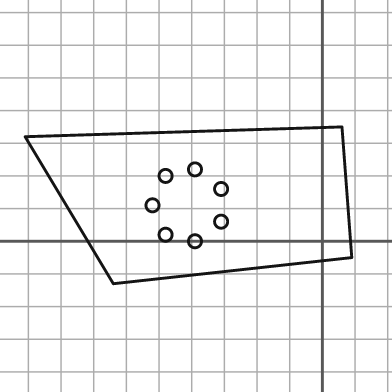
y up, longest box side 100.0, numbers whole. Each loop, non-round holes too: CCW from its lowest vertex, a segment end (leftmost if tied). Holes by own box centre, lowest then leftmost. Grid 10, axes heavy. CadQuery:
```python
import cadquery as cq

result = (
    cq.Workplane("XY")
    .moveTo(-64.0, -13.0)
    .lineTo(9.0, -5.0)
    .lineTo(6.0, 35.0)
    .lineTo(-91.0, 32.0)
    .close()
    .moveTo(-39.0, 0.0)
    .circle(2.0)
    .moveTo(-48.0, 2.0)
    .circle(2.0)
    .moveTo(-31.0, 6.0)
    .circle(2.0)
    .moveTo(-52.0, 11.0)
    .circle(2.0)
    .moveTo(-31.0, 16.0)
    .circle(2.0)
    .moveTo(-48.0, 20.0)
    .circle(2.0)
    .moveTo(-39.0, 22.0)
    .circle(2.0)
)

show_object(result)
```